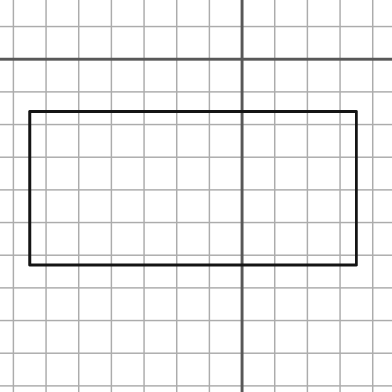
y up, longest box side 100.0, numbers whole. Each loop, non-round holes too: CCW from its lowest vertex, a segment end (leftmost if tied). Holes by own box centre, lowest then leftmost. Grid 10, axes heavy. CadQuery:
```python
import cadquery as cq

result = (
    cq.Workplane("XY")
    .moveTo(-65.0, -63.0)
    .lineTo(35.0, -63.0)
    .lineTo(35.0, -16.0)
    .lineTo(-65.0, -16.0)
    .close()
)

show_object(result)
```